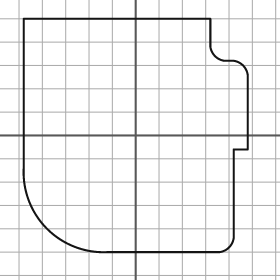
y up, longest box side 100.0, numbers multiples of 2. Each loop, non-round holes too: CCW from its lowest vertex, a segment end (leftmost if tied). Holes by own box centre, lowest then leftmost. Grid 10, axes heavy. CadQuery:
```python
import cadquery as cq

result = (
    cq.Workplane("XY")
    .moveTo(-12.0, -50.0)
    .lineTo(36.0, -50.0)
    .threePointArc((40.0, -48.0), (42.0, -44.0))
    .lineTo(42.0, -6.0)
    .lineTo(48.0, -6.0)
    .lineTo(48.0, 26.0)
    .threePointArc((46.0, 30.0), (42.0, 32.0))
    .lineTo(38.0, 32.0)
    .threePointArc((34.0, 34.0), (32.0, 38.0))
    .lineTo(32.0, 50.0)
    .lineTo(-48.0, 50.0)
    .lineTo(-48.0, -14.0)
    .threePointArc((-38.0, -40.0), (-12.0, -50.0))
    .close()
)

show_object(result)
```